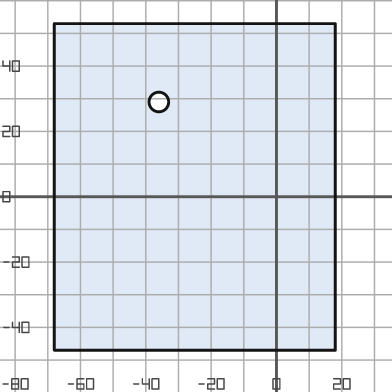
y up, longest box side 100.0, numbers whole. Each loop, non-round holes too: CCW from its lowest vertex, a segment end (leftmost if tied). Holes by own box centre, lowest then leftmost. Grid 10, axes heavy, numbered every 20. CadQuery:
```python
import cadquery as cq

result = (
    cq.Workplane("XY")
    .moveTo(-68.0, -47.0)
    .lineTo(18.0, -47.0)
    .lineTo(18.0, 53.0)
    .lineTo(-68.0, 53.0)
    .close()
    .moveTo(-36.0, 29.0)
    .circle(3.0)
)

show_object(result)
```